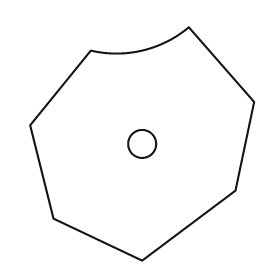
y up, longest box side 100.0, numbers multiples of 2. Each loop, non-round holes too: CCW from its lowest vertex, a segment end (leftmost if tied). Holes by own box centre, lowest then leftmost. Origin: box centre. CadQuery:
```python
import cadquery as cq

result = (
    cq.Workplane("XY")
    .moveTo(0.0, -50.0)
    .lineTo(40.0, -20.0)
    .lineTo(48.0, 18.0)
    .lineTo(20.0, 50.0)
    .threePointArc((0.0, 40.0), (-22.0, 40.0))
    .lineTo(-48.0, 8.0)
    .lineTo(-38.0, -32.0)
    .close()
    .moveTo(0.0, 0.0)
    .circle(6.0)
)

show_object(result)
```